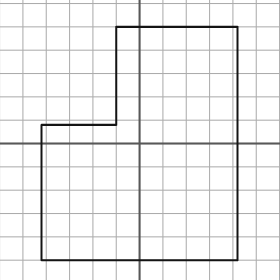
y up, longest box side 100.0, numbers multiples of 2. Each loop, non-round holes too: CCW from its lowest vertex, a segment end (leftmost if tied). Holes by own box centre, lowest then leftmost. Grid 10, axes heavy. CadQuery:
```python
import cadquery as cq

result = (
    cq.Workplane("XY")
    .moveTo(-42.0, -50.0)
    .lineTo(42.0, -50.0)
    .lineTo(42.0, 50.0)
    .lineTo(-10.0, 50.0)
    .lineTo(-10.0, 8.0)
    .lineTo(-42.0, 8.0)
    .close()
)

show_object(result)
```